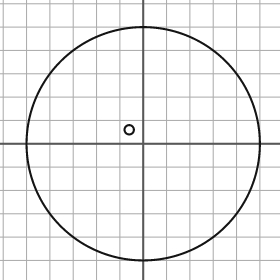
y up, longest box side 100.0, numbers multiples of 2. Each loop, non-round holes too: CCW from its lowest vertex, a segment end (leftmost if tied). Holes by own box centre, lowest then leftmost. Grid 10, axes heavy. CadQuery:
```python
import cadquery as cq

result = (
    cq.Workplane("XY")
    .moveTo(0.0, 0.0)
    .circle(50.0)
    .moveTo(-6.0, 6.0)
    .circle(2.0)
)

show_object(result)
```